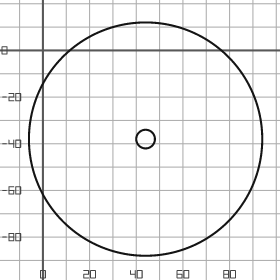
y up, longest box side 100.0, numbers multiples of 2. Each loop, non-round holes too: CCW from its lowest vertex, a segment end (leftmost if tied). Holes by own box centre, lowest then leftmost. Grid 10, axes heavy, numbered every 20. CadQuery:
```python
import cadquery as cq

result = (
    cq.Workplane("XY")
    .moveTo(44.0, -38.0)
    .circle(50.0)
    .moveTo(44.0, -38.0)
    .circle(4.0)
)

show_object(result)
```